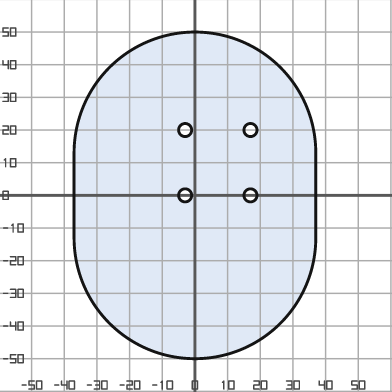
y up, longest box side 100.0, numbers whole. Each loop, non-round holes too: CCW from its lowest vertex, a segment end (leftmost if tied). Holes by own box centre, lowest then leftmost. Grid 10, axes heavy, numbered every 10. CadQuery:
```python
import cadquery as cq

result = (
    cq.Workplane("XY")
    .moveTo(-37.0, -13.0)
    .threePointArc((0.0, -50.0), (37.0, -13.0))
    .lineTo(37.0, 13.0)
    .threePointArc((0.0, 50.0), (-37.0, 13.0))
    .close()
    .moveTo(-3.0, 0.0)
    .circle(2.0)
    .moveTo(17.0, 0.0)
    .circle(2.0)
    .moveTo(-3.0, 20.0)
    .circle(2.0)
    .moveTo(17.0, 20.0)
    .circle(2.0)
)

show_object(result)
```